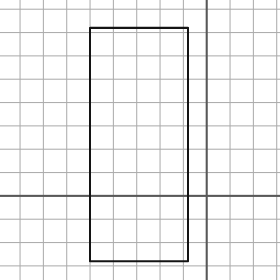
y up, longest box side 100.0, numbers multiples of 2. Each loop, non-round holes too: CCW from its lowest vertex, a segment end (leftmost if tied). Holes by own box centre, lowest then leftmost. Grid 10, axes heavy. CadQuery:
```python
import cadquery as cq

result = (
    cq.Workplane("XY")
    .moveTo(-50.0, -28.0)
    .lineTo(-8.0, -28.0)
    .lineTo(-8.0, 72.0)
    .lineTo(-50.0, 72.0)
    .close()
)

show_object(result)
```